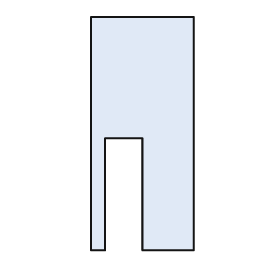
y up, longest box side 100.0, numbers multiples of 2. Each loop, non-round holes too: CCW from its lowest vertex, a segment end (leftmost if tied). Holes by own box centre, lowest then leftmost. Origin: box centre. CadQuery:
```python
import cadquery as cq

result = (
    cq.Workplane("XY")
    .moveTo(-22.0, -50.0)
    .lineTo(-16.0, -50.0)
    .lineTo(-16.0, -2.0)
    .lineTo(0.0, -2.0)
    .lineTo(0.0, -50.0)
    .lineTo(22.0, -50.0)
    .lineTo(22.0, 50.0)
    .lineTo(-22.0, 50.0)
    .close()
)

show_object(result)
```